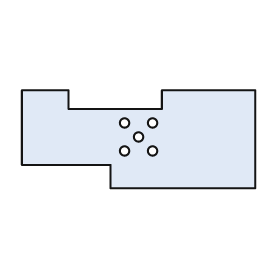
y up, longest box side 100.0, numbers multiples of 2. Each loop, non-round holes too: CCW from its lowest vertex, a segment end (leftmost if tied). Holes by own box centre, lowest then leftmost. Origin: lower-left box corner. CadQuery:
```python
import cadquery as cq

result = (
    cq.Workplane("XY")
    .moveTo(38.0, 0.0)
    .lineTo(100.0, 0.0)
    .lineTo(100.0, 42.0)
    .lineTo(60.0, 42.0)
    .lineTo(60.0, 34.0)
    .lineTo(20.0, 34.0)
    .lineTo(20.0, 42.0)
    .lineTo(0.0, 42.0)
    .lineTo(0.0, 10.0)
    .lineTo(38.0, 10.0)
    .close()
    .moveTo(44.0, 16.0)
    .circle(2.0)
    .moveTo(56.0, 16.0)
    .circle(2.0)
    .moveTo(50.0, 22.0)
    .circle(2.0)
    .moveTo(44.0, 28.0)
    .circle(2.0)
    .moveTo(56.0, 28.0)
    .circle(2.0)
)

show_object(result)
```